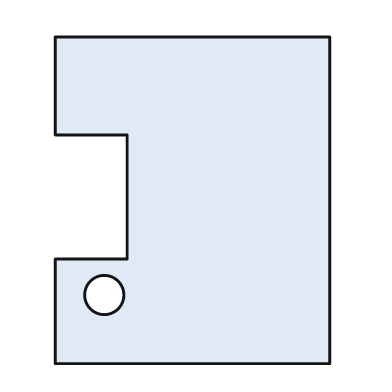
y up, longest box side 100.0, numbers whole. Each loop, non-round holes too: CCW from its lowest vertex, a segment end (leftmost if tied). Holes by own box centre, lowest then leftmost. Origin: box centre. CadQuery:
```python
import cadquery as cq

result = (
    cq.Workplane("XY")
    .moveTo(-42.0, -50.0)
    .lineTo(42.0, -50.0)
    .lineTo(42.0, 50.0)
    .lineTo(-42.0, 50.0)
    .lineTo(-42.0, 20.0)
    .lineTo(-20.0, 20.0)
    .lineTo(-20.0, -18.0)
    .lineTo(-42.0, -18.0)
    .close()
    .moveTo(-27.0, -29.0)
    .circle(6.0)
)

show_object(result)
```